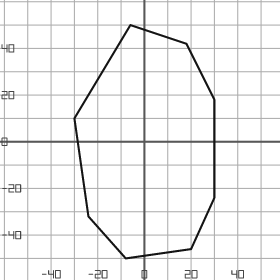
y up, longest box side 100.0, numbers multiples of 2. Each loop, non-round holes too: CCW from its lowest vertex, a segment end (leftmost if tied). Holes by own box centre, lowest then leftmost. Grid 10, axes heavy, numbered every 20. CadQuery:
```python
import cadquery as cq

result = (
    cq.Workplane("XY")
    .moveTo(-8.0, -50.0)
    .lineTo(20.0, -46.0)
    .lineTo(30.0, -24.0)
    .lineTo(30.0, 18.0)
    .lineTo(18.0, 42.0)
    .lineTo(-6.0, 50.0)
    .lineTo(-30.0, 10.0)
    .lineTo(-24.0, -32.0)
    .close()
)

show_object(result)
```